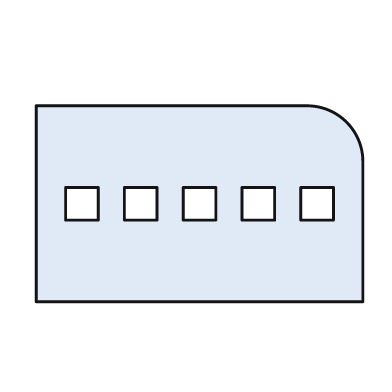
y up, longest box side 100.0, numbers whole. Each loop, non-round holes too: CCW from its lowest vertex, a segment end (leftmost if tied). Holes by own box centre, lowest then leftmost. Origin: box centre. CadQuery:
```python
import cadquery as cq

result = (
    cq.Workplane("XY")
    .moveTo(-50.0, -30.0)
    .lineTo(50.0, -30.0)
    .lineTo(50.0, 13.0)
    .threePointArc((45.0, 25.0), (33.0, 30.0))
    .lineTo(-50.0, 30.0)
    .close()
    .moveTo(-41.0, -5.0)
    .lineTo(-31.0, -5.0)
    .lineTo(-31.0, 5.0)
    .lineTo(-41.0, 5.0)
    .close()
    .moveTo(-23.0, -5.0)
    .lineTo(-13.0, -5.0)
    .lineTo(-13.0, 5.0)
    .lineTo(-23.0, 5.0)
    .close()
    .moveTo(-5.0, -5.0)
    .lineTo(5.0, -5.0)
    .lineTo(5.0, 5.0)
    .lineTo(-5.0, 5.0)
    .close()
    .moveTo(13.0, -5.0)
    .lineTo(23.0, -5.0)
    .lineTo(23.0, 5.0)
    .lineTo(13.0, 5.0)
    .close()
    .moveTo(31.0, -5.0)
    .lineTo(41.0, -5.0)
    .lineTo(41.0, 5.0)
    .lineTo(31.0, 5.0)
    .close()
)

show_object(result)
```